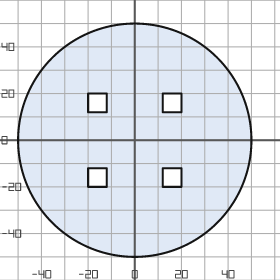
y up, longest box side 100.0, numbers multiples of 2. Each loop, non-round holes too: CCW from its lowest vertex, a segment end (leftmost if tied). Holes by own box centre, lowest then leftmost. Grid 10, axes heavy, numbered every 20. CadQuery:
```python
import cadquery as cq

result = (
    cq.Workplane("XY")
    .moveTo(0.0, 0.0)
    .circle(50.0)
    .moveTo(-20.0, -20.0)
    .lineTo(-12.0, -20.0)
    .lineTo(-12.0, -12.0)
    .lineTo(-20.0, -12.0)
    .close()
    .moveTo(12.0, -20.0)
    .lineTo(20.0, -20.0)
    .lineTo(20.0, -12.0)
    .lineTo(12.0, -12.0)
    .close()
    .moveTo(-20.0, 12.0)
    .lineTo(-12.0, 12.0)
    .lineTo(-12.0, 20.0)
    .lineTo(-20.0, 20.0)
    .close()
    .moveTo(12.0, 12.0)
    .lineTo(20.0, 12.0)
    .lineTo(20.0, 20.0)
    .lineTo(12.0, 20.0)
    .close()
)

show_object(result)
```